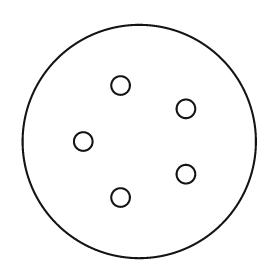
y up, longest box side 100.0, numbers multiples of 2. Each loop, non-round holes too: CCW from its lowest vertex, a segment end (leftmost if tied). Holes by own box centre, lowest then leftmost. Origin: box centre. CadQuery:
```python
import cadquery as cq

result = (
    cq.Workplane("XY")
    .moveTo(0.0, 0.0)
    .circle(50.0)
    .moveTo(-8.0, -24.0)
    .circle(4.0)
    .moveTo(20.0, -14.0)
    .circle(4.0)
    .moveTo(-24.0, 0.0)
    .circle(4.0)
    .moveTo(20.0, 14.0)
    .circle(4.0)
    .moveTo(-8.0, 24.0)
    .circle(4.0)
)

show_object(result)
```